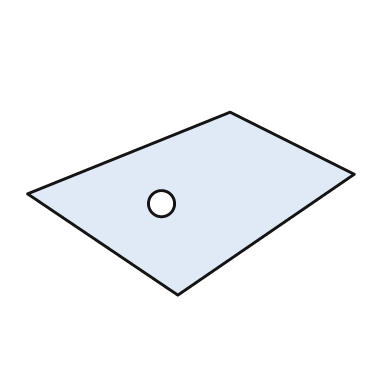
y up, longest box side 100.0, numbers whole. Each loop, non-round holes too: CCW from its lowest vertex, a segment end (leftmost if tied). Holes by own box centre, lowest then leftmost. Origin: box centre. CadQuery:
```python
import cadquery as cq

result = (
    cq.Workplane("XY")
    .moveTo(-4.0, -28.0)
    .lineTo(50.0, 9.0)
    .lineTo(12.0, 28.0)
    .lineTo(-50.0, 3.0)
    .close()
    .moveTo(-9.0, 0.0)
    .circle(4.0)
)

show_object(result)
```